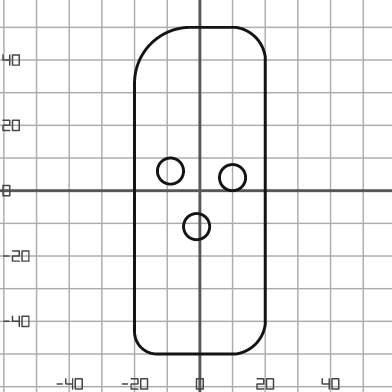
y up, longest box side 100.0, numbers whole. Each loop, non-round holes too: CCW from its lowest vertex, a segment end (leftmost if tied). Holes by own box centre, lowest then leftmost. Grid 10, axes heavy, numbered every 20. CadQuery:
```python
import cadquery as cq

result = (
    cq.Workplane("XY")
    .moveTo(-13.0, -50.0)
    .lineTo(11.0, -50.0)
    .threePointArc((17.0, -47.0), (20.0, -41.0))
    .lineTo(20.0, 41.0)
    .threePointArc((17.0, 47.0), (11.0, 50.0))
    .lineTo(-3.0, 50.0)
    .threePointArc((-15.0, 45.0), (-20.0, 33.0))
    .lineTo(-20.0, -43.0)
    .threePointArc((-18.0, -48.0), (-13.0, -50.0))
    .close()
    .moveTo(-1.0, -11.0)
    .circle(4.0)
    .moveTo(10.0, 4.0)
    .circle(4.0)
    .moveTo(-9.0, 6.0)
    .circle(4.0)
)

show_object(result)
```